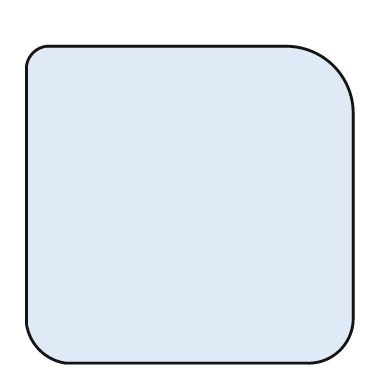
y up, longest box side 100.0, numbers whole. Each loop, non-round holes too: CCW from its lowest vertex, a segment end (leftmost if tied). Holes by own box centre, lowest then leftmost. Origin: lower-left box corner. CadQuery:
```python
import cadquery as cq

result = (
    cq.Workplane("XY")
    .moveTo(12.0, 0.0)
    .lineTo(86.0, 0.0)
    .threePointArc((96.0, 4.0), (100.0, 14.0))
    .lineTo(100.0, 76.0)
    .threePointArc((94.0, 91.0), (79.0, 97.0))
    .lineTo(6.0, 97.0)
    .threePointArc((2.0, 95.0), (0.0, 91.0))
    .lineTo(0.0, 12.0)
    .threePointArc((4.0, 4.0), (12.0, 0.0))
    .close()
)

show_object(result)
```